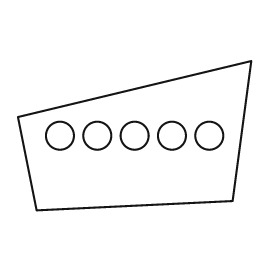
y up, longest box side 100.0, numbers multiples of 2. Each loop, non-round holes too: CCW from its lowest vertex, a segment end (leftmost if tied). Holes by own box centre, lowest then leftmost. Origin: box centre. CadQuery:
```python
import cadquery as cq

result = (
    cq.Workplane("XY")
    .moveTo(-42.0, -32.0)
    .lineTo(42.0, -28.0)
    .lineTo(50.0, 32.0)
    .lineTo(-50.0, 8.0)
    .close()
    .moveTo(-32.0, 0.0)
    .circle(6.0)
    .moveTo(-16.0, 0.0)
    .circle(6.0)
    .moveTo(0.0, 0.0)
    .circle(6.0)
    .moveTo(16.0, 0.0)
    .circle(6.0)
    .moveTo(32.0, 0.0)
    .circle(6.0)
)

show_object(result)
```